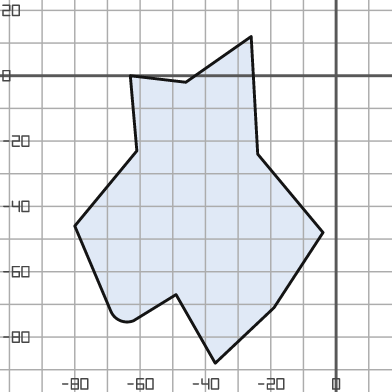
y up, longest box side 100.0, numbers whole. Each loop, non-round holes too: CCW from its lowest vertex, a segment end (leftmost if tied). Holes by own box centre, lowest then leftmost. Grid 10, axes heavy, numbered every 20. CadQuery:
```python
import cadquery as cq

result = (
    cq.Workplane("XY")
    .moveTo(-37.0, -88.0)
    .lineTo(-19.0, -71.0)
    .lineTo(-4.0, -48.0)
    .lineTo(-24.0, -24.0)
    .lineTo(-26.0, 12.0)
    .lineTo(-46.0, -2.0)
    .lineTo(-63.0, 0.0)
    .lineTo(-61.0, -23.0)
    .lineTo(-80.0, -46.0)
    .lineTo(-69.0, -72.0)
    .threePointArc((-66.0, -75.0), (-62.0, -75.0))
    .lineTo(-49.0, -67.0)
    .close()
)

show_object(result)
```